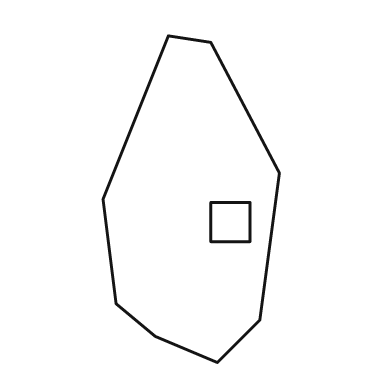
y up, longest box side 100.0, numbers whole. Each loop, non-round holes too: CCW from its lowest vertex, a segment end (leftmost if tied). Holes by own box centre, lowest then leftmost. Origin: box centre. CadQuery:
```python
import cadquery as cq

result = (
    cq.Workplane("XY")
    .moveTo(8.0, -50.0)
    .lineTo(21.0, -37.0)
    .lineTo(27.0, 8.0)
    .lineTo(6.0, 48.0)
    .lineTo(-7.0, 50.0)
    .lineTo(-27.0, 0.0)
    .lineTo(-23.0, -32.0)
    .lineTo(-11.0, -42.0)
    .close()
    .moveTo(6.0, -13.0)
    .lineTo(18.0, -13.0)
    .lineTo(18.0, -1.0)
    .lineTo(6.0, -1.0)
    .close()
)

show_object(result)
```